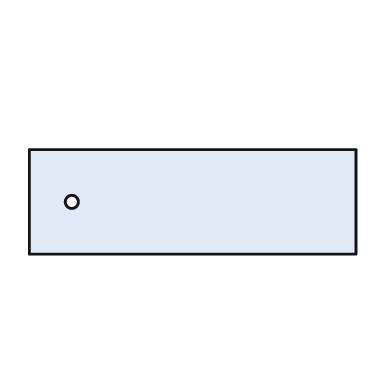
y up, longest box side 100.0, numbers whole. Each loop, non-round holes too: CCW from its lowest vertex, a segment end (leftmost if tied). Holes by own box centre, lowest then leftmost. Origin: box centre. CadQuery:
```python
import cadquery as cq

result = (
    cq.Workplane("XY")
    .moveTo(-50.0, -16.0)
    .lineTo(50.0, -16.0)
    .lineTo(50.0, 16.0)
    .lineTo(-50.0, 16.0)
    .close()
    .moveTo(-37.0, 0.0)
    .circle(2.0)
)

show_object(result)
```